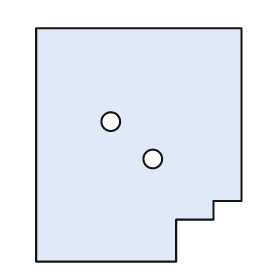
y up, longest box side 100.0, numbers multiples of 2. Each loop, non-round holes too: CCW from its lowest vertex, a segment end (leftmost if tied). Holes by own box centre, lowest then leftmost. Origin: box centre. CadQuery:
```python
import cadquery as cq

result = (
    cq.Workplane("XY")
    .moveTo(-44.0, -50.0)
    .lineTo(16.0, -50.0)
    .lineTo(16.0, -32.0)
    .lineTo(32.0, -32.0)
    .lineTo(32.0, -24.0)
    .lineTo(44.0, -24.0)
    .lineTo(44.0, 50.0)
    .lineTo(-44.0, 50.0)
    .close()
    .moveTo(6.0, -6.0)
    .circle(4.0)
    .moveTo(-12.0, 10.0)
    .circle(4.0)
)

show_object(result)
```